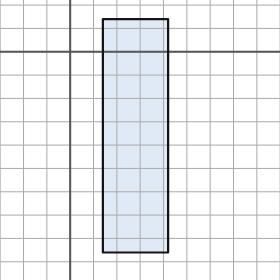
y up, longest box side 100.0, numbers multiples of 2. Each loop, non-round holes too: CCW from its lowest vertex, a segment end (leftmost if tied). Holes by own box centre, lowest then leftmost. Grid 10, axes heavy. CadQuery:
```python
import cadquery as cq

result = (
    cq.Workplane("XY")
    .moveTo(14.0, -86.0)
    .lineTo(42.0, -86.0)
    .lineTo(42.0, 14.0)
    .lineTo(14.0, 14.0)
    .close()
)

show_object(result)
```